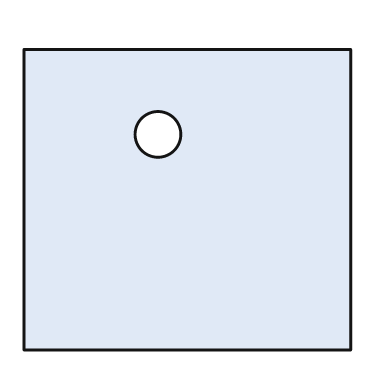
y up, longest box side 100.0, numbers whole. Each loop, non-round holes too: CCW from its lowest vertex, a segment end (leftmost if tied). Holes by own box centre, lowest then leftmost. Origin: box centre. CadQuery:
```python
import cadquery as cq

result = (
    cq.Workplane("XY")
    .moveTo(-50.0, -46.0)
    .lineTo(50.0, -46.0)
    .lineTo(50.0, 46.0)
    .lineTo(-50.0, 46.0)
    .close()
    .moveTo(-9.0, 20.0)
    .circle(7.0)
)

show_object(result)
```